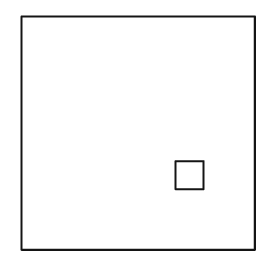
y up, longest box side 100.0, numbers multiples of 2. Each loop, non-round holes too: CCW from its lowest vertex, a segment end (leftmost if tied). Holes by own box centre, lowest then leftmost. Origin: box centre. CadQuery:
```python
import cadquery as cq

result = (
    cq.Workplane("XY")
    .moveTo(-50.0, -50.0)
    .lineTo(50.0, -50.0)
    .lineTo(50.0, 50.0)
    .lineTo(-50.0, 50.0)
    .close()
    .moveTo(16.0, -24.0)
    .lineTo(28.0, -24.0)
    .lineTo(28.0, -12.0)
    .lineTo(16.0, -12.0)
    .close()
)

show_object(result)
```